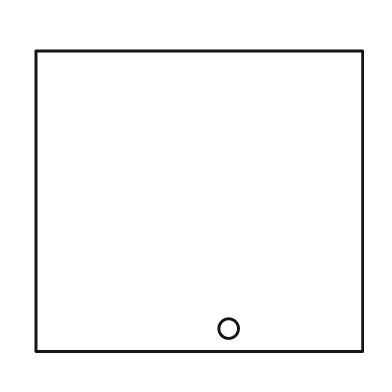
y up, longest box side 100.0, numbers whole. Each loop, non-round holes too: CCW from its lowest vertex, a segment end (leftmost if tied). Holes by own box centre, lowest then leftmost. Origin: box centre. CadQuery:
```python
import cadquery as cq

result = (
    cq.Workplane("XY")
    .moveTo(-50.0, -46.0)
    .lineTo(50.0, -46.0)
    .lineTo(50.0, 46.0)
    .lineTo(-50.0, 46.0)
    .close()
    .moveTo(9.0, -39.0)
    .circle(3.0)
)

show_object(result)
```